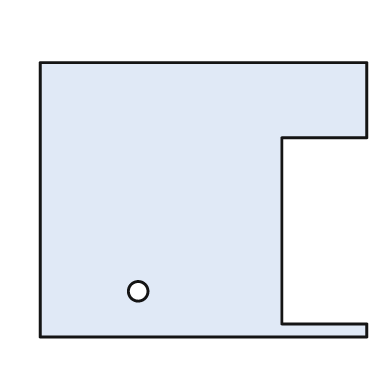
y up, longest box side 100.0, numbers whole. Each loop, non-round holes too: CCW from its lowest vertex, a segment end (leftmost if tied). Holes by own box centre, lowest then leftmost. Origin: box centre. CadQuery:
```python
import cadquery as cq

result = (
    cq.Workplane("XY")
    .moveTo(-50.0, -42.0)
    .lineTo(50.0, -42.0)
    .lineTo(50.0, -38.0)
    .lineTo(24.0, -38.0)
    .lineTo(24.0, 19.0)
    .lineTo(50.0, 19.0)
    .lineTo(50.0, 42.0)
    .lineTo(-50.0, 42.0)
    .close()
    .moveTo(-20.0, -28.0)
    .circle(3.0)
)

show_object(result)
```